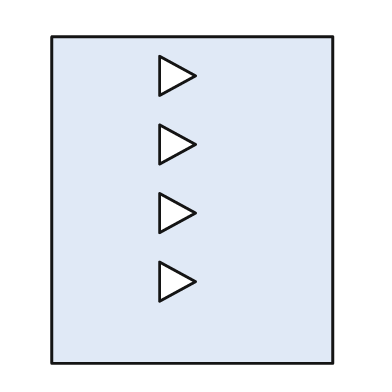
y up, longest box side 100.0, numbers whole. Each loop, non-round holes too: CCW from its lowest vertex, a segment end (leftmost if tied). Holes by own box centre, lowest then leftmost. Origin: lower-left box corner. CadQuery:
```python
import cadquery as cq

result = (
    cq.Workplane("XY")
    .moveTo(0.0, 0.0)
    .lineTo(86.0, 0.0)
    .lineTo(86.0, 100.0)
    .lineTo(0.0, 100.0)
    .close()
    .moveTo(33.0, 19.0)
    .lineTo(44.0, 25.0)
    .lineTo(33.0, 31.0)
    .close()
    .moveTo(33.0, 40.0)
    .lineTo(44.0, 46.0)
    .lineTo(33.0, 52.0)
    .close()
    .moveTo(33.0, 61.0)
    .lineTo(44.0, 67.0)
    .lineTo(33.0, 73.0)
    .close()
    .moveTo(33.0, 82.0)
    .lineTo(44.0, 88.0)
    .lineTo(33.0, 94.0)
    .close()
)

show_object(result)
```